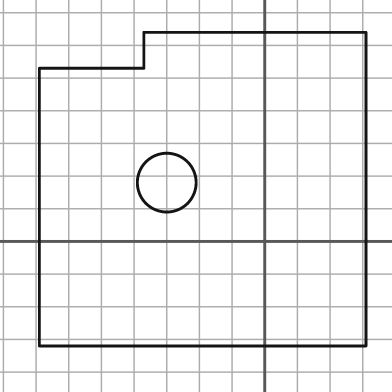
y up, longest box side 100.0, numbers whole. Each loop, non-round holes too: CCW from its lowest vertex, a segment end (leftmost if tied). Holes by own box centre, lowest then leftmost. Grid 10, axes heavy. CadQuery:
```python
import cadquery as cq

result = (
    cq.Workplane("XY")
    .moveTo(-69.0, -32.0)
    .lineTo(31.0, -32.0)
    .lineTo(31.0, 64.0)
    .lineTo(-37.0, 64.0)
    .lineTo(-37.0, 53.0)
    .lineTo(-69.0, 53.0)
    .close()
    .moveTo(-30.0, 18.0)
    .circle(9.0)
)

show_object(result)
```